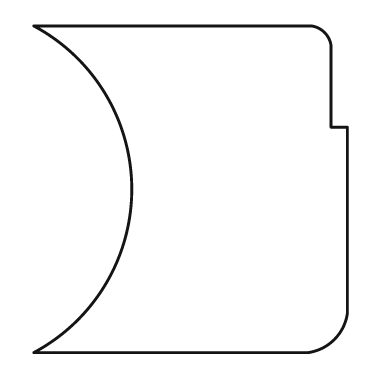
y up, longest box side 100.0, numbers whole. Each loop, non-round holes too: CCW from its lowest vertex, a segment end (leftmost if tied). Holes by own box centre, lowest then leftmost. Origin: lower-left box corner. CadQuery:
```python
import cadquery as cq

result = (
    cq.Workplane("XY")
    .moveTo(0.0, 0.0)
    .lineTo(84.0, 0.0)
    .threePointArc((92.0, 4.0), (96.0, 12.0))
    .lineTo(96.0, 69.0)
    .lineTo(91.0, 69.0)
    .lineTo(91.0, 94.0)
    .threePointArc((89.0, 98.0), (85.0, 100.0))
    .lineTo(0.0, 100.0)
    .threePointArc((30.0, 50.0), (0.0, 0.0))
    .close()
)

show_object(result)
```